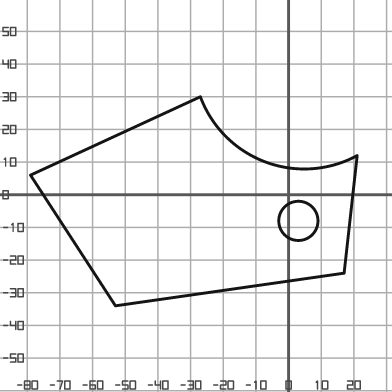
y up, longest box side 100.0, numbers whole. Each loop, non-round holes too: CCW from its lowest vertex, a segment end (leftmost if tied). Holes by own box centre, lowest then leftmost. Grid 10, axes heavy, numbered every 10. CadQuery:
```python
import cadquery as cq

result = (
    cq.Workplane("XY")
    .moveTo(-53.0, -34.0)
    .lineTo(17.0, -24.0)
    .lineTo(21.0, 12.0)
    .threePointArc((-7.0, 10.0), (-27.0, 30.0))
    .lineTo(-79.0, 6.0)
    .close()
    .moveTo(3.0, -8.0)
    .circle(6.0)
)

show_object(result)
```